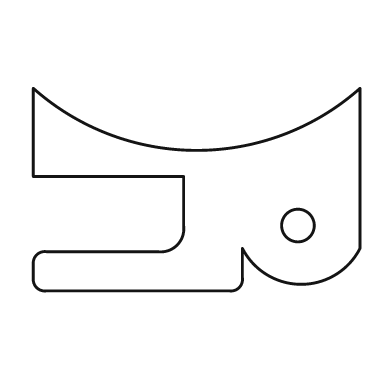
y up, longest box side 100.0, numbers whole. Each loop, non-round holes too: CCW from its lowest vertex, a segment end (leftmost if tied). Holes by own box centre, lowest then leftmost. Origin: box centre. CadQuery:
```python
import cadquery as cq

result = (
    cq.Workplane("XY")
    .moveTo(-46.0, -31.0)
    .lineTo(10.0, -31.0)
    .threePointArc((13.0, -30.0), (14.0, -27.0))
    .lineTo(14.0, -18.0)
    .threePointArc((32.0, -29.0), (50.0, -18.0))
    .lineTo(50.0, 31.0)
    .threePointArc((0.0, 12.0), (-50.0, 31.0))
    .lineTo(-50.0, 4.0)
    .lineTo(-4.0, 4.0)
    .lineTo(-4.0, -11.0)
    .threePointArc((-6.0, -17.0), (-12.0, -19.0))
    .lineTo(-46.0, -19.0)
    .threePointArc((-49.0, -20.0), (-50.0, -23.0))
    .lineTo(-50.0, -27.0)
    .threePointArc((-49.0, -30.0), (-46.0, -31.0))
    .close()
    .moveTo(31.0, -11.0)
    .circle(5.0)
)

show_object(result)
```